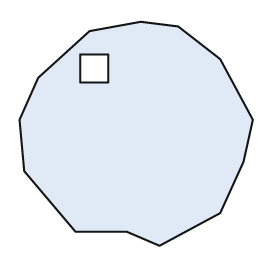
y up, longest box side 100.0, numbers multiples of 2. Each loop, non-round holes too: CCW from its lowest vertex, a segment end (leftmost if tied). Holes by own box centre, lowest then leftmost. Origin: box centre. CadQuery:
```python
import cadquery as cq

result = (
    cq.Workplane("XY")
    .moveTo(10.0, -48.0)
    .lineTo(36.0, -34.0)
    .lineTo(46.0, -12.0)
    .lineTo(50.0, 6.0)
    .lineTo(36.0, 32.0)
    .lineTo(18.0, 46.0)
    .lineTo(2.0, 48.0)
    .lineTo(-20.0, 44.0)
    .lineTo(-42.0, 24.0)
    .lineTo(-50.0, 6.0)
    .lineTo(-48.0, -16.0)
    .lineTo(-26.0, -42.0)
    .lineTo(-4.0, -42.0)
    .close()
    .moveTo(-24.0, 22.0)
    .lineTo(-12.0, 22.0)
    .lineTo(-12.0, 34.0)
    .lineTo(-24.0, 34.0)
    .close()
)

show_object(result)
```